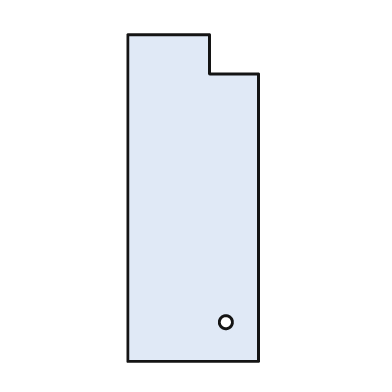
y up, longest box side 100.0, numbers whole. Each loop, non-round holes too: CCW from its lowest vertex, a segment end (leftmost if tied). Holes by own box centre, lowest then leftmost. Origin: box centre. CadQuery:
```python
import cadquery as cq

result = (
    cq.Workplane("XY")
    .moveTo(-20.0, -50.0)
    .lineTo(20.0, -50.0)
    .lineTo(20.0, 38.0)
    .lineTo(5.0, 38.0)
    .lineTo(5.0, 50.0)
    .lineTo(-20.0, 50.0)
    .close()
    .moveTo(10.0, -38.0)
    .circle(2.0)
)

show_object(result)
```